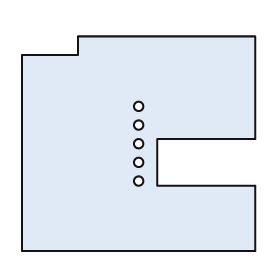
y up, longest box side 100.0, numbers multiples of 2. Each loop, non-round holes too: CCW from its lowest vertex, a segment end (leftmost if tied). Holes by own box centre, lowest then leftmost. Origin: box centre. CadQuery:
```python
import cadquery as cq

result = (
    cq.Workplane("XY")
    .moveTo(-50.0, -46.0)
    .lineTo(50.0, -46.0)
    .lineTo(50.0, -18.0)
    .lineTo(8.0, -18.0)
    .lineTo(8.0, 2.0)
    .lineTo(50.0, 2.0)
    .lineTo(50.0, 46.0)
    .lineTo(-26.0, 46.0)
    .lineTo(-26.0, 38.0)
    .lineTo(-50.0, 38.0)
    .close()
    .moveTo(0.0, -16.0)
    .circle(2.0)
    .moveTo(0.0, -8.0)
    .circle(2.0)
    .moveTo(0.0, 0.0)
    .circle(2.0)
    .moveTo(0.0, 8.0)
    .circle(2.0)
    .moveTo(0.0, 16.0)
    .circle(2.0)
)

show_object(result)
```